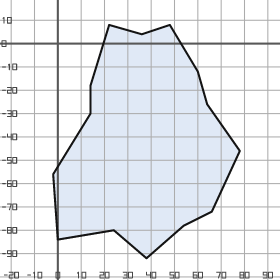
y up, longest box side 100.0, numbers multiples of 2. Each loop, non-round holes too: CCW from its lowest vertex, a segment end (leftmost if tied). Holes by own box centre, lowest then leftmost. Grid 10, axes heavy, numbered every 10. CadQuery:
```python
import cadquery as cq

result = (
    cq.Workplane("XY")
    .moveTo(38.0, -92.0)
    .lineTo(54.0, -78.0)
    .lineTo(66.0, -72.0)
    .lineTo(78.0, -46.0)
    .lineTo(64.0, -26.0)
    .lineTo(60.0, -12.0)
    .lineTo(48.0, 8.0)
    .lineTo(36.0, 4.0)
    .lineTo(22.0, 8.0)
    .lineTo(14.0, -18.0)
    .lineTo(14.0, -30.0)
    .lineTo(-2.0, -56.0)
    .lineTo(0.0, -84.0)
    .lineTo(24.0, -80.0)
    .close()
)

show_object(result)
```